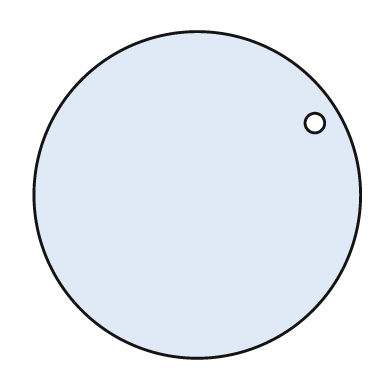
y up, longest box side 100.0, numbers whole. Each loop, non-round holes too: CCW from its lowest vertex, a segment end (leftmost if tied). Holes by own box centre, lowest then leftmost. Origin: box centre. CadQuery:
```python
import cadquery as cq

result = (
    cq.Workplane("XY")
    .moveTo(0.0, 0.0)
    .circle(50.0)
    .moveTo(36.0, 22.0)
    .circle(3.0)
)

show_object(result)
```